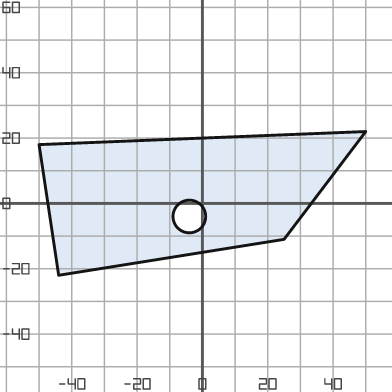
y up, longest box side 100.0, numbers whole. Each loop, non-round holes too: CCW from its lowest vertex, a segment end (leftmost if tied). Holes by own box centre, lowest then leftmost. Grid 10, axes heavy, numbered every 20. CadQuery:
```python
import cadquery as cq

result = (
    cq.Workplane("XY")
    .moveTo(-44.0, -22.0)
    .lineTo(25.0, -11.0)
    .lineTo(50.0, 22.0)
    .lineTo(-50.0, 18.0)
    .close()
    .moveTo(-4.0, -4.0)
    .circle(5.0)
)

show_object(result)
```